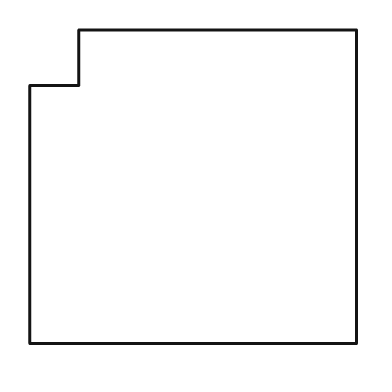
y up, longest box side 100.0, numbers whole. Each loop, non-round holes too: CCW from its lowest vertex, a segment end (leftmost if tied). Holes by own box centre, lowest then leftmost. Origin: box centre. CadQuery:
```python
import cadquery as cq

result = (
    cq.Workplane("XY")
    .moveTo(-50.0, -48.0)
    .lineTo(50.0, -48.0)
    .lineTo(50.0, 48.0)
    .lineTo(-35.0, 48.0)
    .lineTo(-35.0, 31.0)
    .lineTo(-50.0, 31.0)
    .close()
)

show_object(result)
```